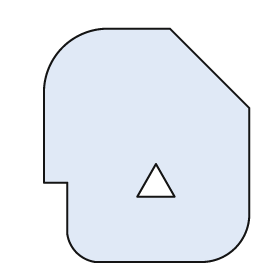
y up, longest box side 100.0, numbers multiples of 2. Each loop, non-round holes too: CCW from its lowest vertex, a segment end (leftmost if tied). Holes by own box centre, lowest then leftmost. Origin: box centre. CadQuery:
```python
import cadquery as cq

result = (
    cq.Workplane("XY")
    .moveTo(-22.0, -50.0)
    .lineTo(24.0, -50.0)
    .threePointArc((38.0, -44.0), (44.0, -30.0))
    .lineTo(44.0, 16.0)
    .lineTo(10.0, 50.0)
    .lineTo(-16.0, 50.0)
    .threePointArc((-36.0, 42.0), (-44.0, 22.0))
    .lineTo(-44.0, -16.0)
    .lineTo(-34.0, -16.0)
    .lineTo(-34.0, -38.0)
    .threePointArc((-30.0, -46.0), (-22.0, -50.0))
    .close()
    .moveTo(-4.0, -22.0)
    .lineTo(12.0, -22.0)
    .lineTo(4.0, -8.0)
    .close()
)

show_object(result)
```